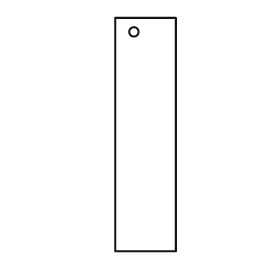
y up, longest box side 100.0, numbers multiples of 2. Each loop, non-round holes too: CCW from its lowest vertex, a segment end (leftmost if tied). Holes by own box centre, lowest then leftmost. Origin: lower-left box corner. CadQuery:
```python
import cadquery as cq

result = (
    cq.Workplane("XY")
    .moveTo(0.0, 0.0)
    .lineTo(26.0, 0.0)
    .lineTo(26.0, 100.0)
    .lineTo(0.0, 100.0)
    .close()
    .moveTo(8.0, 94.0)
    .circle(2.0)
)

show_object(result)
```